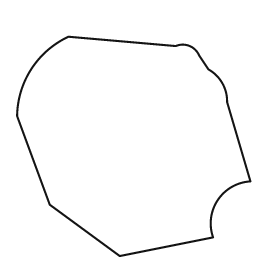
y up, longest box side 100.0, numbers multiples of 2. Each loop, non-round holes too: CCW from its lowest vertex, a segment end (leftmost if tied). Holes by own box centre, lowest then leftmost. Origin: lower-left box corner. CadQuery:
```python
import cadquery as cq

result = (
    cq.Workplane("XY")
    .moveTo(44.0, 0.0)
    .lineTo(84.0, 8.0)
    .threePointArc((86.0, 24.0), (100.0, 32.0))
    .lineTo(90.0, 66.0)
    .threePointArc((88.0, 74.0), (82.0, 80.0))
    .lineTo(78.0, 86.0)
    .threePointArc((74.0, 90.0), (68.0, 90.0))
    .lineTo(22.0, 94.0)
    .threePointArc((6.0, 80.0), (0.0, 60.0))
    .lineTo(14.0, 22.0)
    .close()
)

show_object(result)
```